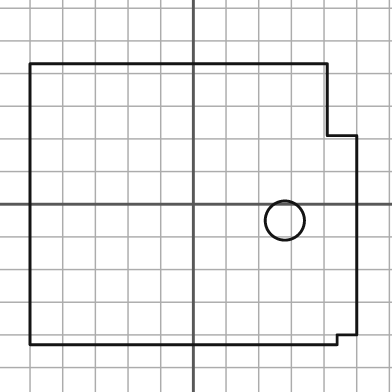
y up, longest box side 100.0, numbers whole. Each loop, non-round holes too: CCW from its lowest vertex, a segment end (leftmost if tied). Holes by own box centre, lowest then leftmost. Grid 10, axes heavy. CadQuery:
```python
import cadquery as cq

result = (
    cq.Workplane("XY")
    .moveTo(-50.0, -43.0)
    .lineTo(44.0, -43.0)
    .lineTo(44.0, -40.0)
    .lineTo(50.0, -40.0)
    .lineTo(50.0, 21.0)
    .lineTo(41.0, 21.0)
    .lineTo(41.0, 43.0)
    .lineTo(-50.0, 43.0)
    .close()
    .moveTo(28.0, -5.0)
    .circle(6.0)
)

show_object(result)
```